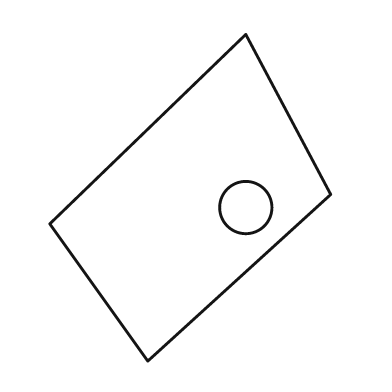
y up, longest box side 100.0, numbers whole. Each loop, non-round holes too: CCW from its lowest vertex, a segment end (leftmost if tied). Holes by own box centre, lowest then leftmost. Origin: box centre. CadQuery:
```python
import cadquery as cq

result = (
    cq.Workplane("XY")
    .moveTo(-13.0, -50.0)
    .lineTo(43.0, 1.0)
    .lineTo(17.0, 50.0)
    .lineTo(-43.0, -8.0)
    .close()
    .moveTo(17.0, -3.0)
    .circle(8.0)
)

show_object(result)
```